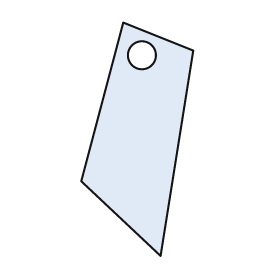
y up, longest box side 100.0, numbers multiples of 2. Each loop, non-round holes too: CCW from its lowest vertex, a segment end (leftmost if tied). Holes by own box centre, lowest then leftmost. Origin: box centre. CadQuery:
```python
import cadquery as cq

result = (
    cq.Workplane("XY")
    .moveTo(10.0, -50.0)
    .lineTo(24.0, 38.0)
    .lineTo(-6.0, 50.0)
    .lineTo(-24.0, -18.0)
    .close()
    .moveTo(2.0, 36.0)
    .circle(6.0)
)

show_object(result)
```